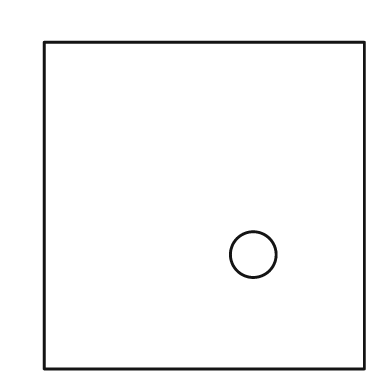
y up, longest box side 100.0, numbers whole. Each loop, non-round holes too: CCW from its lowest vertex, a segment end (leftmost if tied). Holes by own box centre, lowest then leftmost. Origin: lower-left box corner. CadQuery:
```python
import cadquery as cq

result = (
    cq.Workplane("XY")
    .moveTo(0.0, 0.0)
    .lineTo(98.0, 0.0)
    .lineTo(98.0, 100.0)
    .lineTo(0.0, 100.0)
    .close()
    .moveTo(64.0, 35.0)
    .circle(7.0)
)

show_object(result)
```